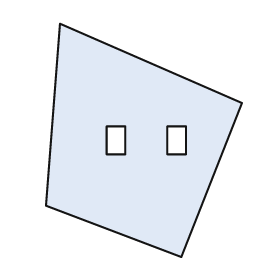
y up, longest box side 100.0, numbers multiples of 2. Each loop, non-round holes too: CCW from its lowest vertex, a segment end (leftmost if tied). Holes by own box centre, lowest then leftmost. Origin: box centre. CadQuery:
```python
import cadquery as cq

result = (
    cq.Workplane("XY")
    .moveTo(16.0, -50.0)
    .lineTo(42.0, 16.0)
    .lineTo(-36.0, 50.0)
    .lineTo(-42.0, -28.0)
    .close()
    .moveTo(-16.0, -6.0)
    .lineTo(-8.0, -6.0)
    .lineTo(-8.0, 6.0)
    .lineTo(-16.0, 6.0)
    .close()
    .moveTo(10.0, -6.0)
    .lineTo(18.0, -6.0)
    .lineTo(18.0, 6.0)
    .lineTo(10.0, 6.0)
    .close()
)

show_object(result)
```